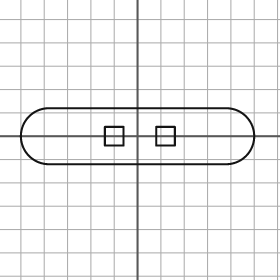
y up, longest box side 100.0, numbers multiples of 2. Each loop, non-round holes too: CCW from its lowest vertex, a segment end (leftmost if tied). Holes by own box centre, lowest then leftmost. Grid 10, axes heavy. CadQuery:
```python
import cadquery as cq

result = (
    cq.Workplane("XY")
    .moveTo(-38.0, -12.0)
    .lineTo(38.0, -12.0)
    .threePointArc((50.0, 0.0), (38.0, 12.0))
    .lineTo(-38.0, 12.0)
    .threePointArc((-50.0, 0.0), (-38.0, -12.0))
    .close()
    .moveTo(-14.0, -4.0)
    .lineTo(-6.0, -4.0)
    .lineTo(-6.0, 4.0)
    .lineTo(-14.0, 4.0)
    .close()
    .moveTo(8.0, -4.0)
    .lineTo(16.0, -4.0)
    .lineTo(16.0, 4.0)
    .lineTo(8.0, 4.0)
    .close()
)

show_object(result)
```